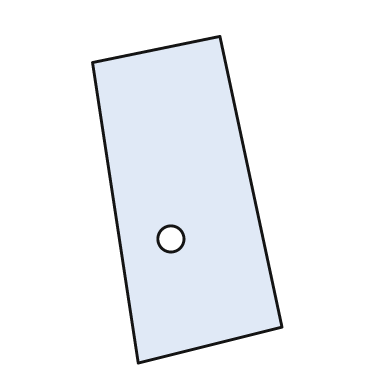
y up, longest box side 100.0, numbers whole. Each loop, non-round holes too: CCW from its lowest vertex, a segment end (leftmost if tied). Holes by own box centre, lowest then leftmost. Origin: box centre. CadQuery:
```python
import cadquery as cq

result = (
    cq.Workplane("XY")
    .moveTo(-15.0, -50.0)
    .lineTo(29.0, -39.0)
    .lineTo(10.0, 50.0)
    .lineTo(-29.0, 42.0)
    .close()
    .moveTo(-5.0, -12.0)
    .circle(4.0)
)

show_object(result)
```